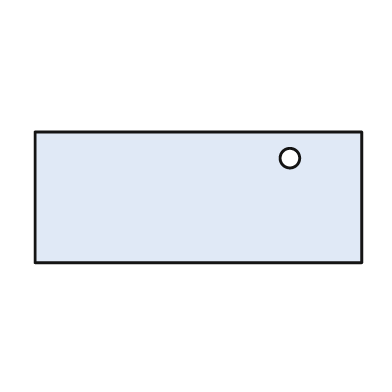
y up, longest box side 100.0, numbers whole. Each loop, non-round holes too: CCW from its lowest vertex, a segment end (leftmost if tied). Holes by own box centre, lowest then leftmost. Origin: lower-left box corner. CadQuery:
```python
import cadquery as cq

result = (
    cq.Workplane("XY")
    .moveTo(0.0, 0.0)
    .lineTo(100.0, 0.0)
    .lineTo(100.0, 40.0)
    .lineTo(0.0, 40.0)
    .close()
    .moveTo(78.0, 32.0)
    .circle(3.0)
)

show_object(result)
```